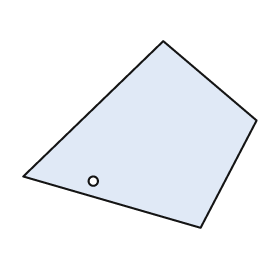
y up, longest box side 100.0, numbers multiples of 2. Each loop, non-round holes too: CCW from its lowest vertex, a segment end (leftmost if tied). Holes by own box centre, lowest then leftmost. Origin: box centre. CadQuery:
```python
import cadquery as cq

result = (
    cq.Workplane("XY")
    .moveTo(26.0, -40.0)
    .lineTo(50.0, 6.0)
    .lineTo(10.0, 40.0)
    .lineTo(-50.0, -18.0)
    .close()
    .moveTo(-20.0, -20.0)
    .circle(2.0)
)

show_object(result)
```